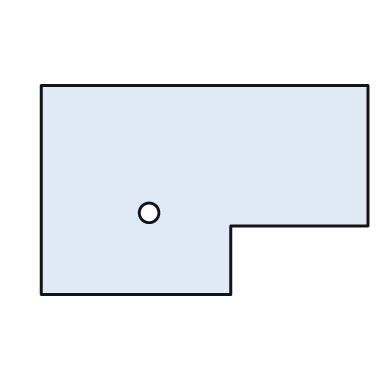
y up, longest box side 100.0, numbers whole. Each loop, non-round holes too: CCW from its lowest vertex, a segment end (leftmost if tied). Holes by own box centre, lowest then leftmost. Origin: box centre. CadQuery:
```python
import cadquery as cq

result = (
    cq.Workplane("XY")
    .moveTo(-50.0, -32.0)
    .lineTo(8.0, -32.0)
    .lineTo(8.0, -11.0)
    .lineTo(50.0, -11.0)
    .lineTo(50.0, 32.0)
    .lineTo(-50.0, 32.0)
    .close()
    .moveTo(-17.0, -7.0)
    .circle(3.0)
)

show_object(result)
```